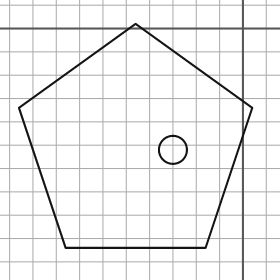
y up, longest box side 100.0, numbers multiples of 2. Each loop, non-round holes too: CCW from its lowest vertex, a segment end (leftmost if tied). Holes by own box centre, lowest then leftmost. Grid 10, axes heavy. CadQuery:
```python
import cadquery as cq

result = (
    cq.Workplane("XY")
    .moveTo(-76.0, -94.0)
    .lineTo(-16.0, -94.0)
    .lineTo(4.0, -34.0)
    .lineTo(-46.0, 2.0)
    .lineTo(-96.0, -34.0)
    .close()
    .moveTo(-30.0, -52.0)
    .circle(6.0)
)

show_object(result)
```